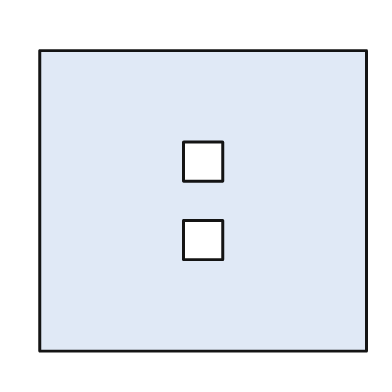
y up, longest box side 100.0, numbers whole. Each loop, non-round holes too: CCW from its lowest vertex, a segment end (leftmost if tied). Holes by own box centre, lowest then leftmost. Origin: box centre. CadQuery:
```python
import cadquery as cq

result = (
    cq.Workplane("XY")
    .moveTo(-50.0, -46.0)
    .lineTo(50.0, -46.0)
    .lineTo(50.0, 46.0)
    .lineTo(-50.0, 46.0)
    .close()
    .moveTo(-6.0, -18.0)
    .lineTo(6.0, -18.0)
    .lineTo(6.0, -6.0)
    .lineTo(-6.0, -6.0)
    .close()
    .moveTo(-6.0, 6.0)
    .lineTo(6.0, 6.0)
    .lineTo(6.0, 18.0)
    .lineTo(-6.0, 18.0)
    .close()
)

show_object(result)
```